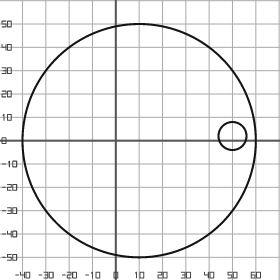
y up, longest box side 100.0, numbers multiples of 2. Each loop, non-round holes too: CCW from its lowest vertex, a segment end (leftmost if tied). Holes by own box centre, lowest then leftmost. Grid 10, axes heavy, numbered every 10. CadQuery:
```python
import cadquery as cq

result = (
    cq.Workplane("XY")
    .moveTo(10.0, 0.0)
    .circle(50.0)
    .moveTo(50.0, 2.0)
    .circle(6.0)
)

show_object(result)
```